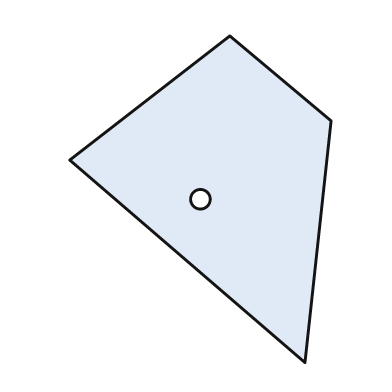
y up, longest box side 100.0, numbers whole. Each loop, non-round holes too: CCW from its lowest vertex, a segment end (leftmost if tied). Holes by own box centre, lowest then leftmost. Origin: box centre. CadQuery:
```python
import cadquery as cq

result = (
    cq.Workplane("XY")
    .moveTo(32.0, -50.0)
    .lineTo(40.0, 24.0)
    .lineTo(9.0, 50.0)
    .lineTo(-40.0, 12.0)
    .close()
    .moveTo(0.0, 0.0)
    .circle(3.0)
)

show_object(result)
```